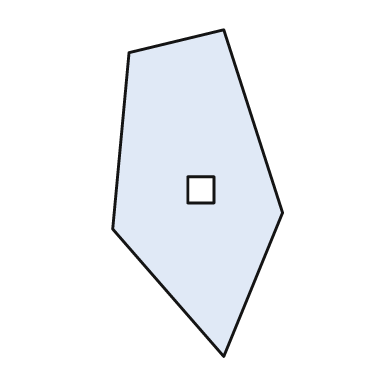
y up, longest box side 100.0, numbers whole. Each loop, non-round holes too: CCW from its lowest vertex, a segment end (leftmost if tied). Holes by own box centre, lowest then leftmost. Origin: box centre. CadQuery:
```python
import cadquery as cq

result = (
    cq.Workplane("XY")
    .moveTo(8.0, -50.0)
    .lineTo(26.0, -6.0)
    .lineTo(8.0, 50.0)
    .lineTo(-21.0, 43.0)
    .lineTo(-26.0, -11.0)
    .close()
    .moveTo(-3.0, -3.0)
    .lineTo(5.0, -3.0)
    .lineTo(5.0, 5.0)
    .lineTo(-3.0, 5.0)
    .close()
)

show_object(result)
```